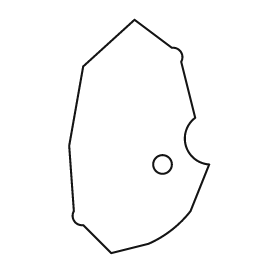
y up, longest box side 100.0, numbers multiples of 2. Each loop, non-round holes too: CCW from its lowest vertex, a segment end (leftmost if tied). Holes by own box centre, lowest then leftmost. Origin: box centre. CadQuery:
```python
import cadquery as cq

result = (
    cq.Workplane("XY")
    .moveTo(-12.0, -50.0)
    .lineTo(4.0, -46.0)
    .threePointArc((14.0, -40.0), (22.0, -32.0))
    .lineTo(30.0, -12.0)
    .threePointArc((20.0, -4.0), (24.0, 8.0))
    .lineTo(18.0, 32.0)
    .threePointArc((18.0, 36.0), (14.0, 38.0))
    .lineTo(-2.0, 50.0)
    .lineTo(-24.0, 30.0)
    .lineTo(-30.0, -4.0)
    .lineTo(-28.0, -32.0)
    .threePointArc((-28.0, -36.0), (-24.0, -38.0))
    .close()
    .moveTo(10.0, -12.0)
    .circle(4.0)
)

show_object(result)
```